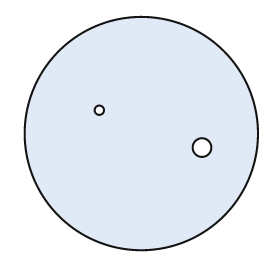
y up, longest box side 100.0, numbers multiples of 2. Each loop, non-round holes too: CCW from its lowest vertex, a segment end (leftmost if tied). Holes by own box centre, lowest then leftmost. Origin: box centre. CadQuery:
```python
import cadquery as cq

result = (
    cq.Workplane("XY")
    .moveTo(0.0, 0.0)
    .circle(50.0)
    .moveTo(26.0, -6.0)
    .circle(4.0)
    .moveTo(-18.0, 10.0)
    .circle(2.0)
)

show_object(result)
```